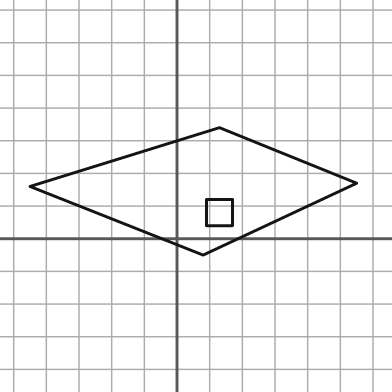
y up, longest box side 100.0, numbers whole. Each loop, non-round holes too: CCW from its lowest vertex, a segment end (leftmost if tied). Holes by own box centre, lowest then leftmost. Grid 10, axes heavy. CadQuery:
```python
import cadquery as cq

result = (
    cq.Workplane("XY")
    .moveTo(8.0, -5.0)
    .lineTo(55.0, 17.0)
    .lineTo(13.0, 34.0)
    .lineTo(-45.0, 16.0)
    .close()
    .moveTo(9.0, 4.0)
    .lineTo(17.0, 4.0)
    .lineTo(17.0, 12.0)
    .lineTo(9.0, 12.0)
    .close()
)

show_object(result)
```